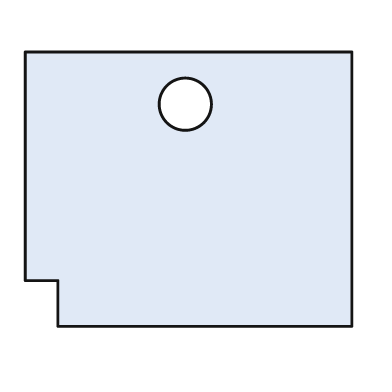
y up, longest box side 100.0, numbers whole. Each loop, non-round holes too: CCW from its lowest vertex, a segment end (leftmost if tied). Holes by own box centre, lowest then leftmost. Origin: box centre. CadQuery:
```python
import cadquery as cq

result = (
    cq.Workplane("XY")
    .moveTo(-40.0, -42.0)
    .lineTo(50.0, -42.0)
    .lineTo(50.0, 42.0)
    .lineTo(-50.0, 42.0)
    .lineTo(-50.0, -28.0)
    .lineTo(-40.0, -28.0)
    .close()
    .moveTo(-1.0, 26.0)
    .circle(8.0)
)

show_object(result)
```